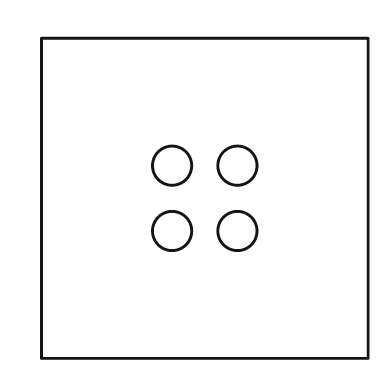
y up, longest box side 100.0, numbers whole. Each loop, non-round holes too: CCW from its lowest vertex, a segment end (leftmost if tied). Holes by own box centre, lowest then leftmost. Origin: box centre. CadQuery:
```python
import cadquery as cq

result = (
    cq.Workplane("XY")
    .moveTo(-50.0, -49.0)
    .lineTo(50.0, -49.0)
    .lineTo(50.0, 49.0)
    .lineTo(-50.0, 49.0)
    .close()
    .moveTo(-10.0, -10.0)
    .circle(6.0)
    .moveTo(10.0, -10.0)
    .circle(6.0)
    .moveTo(-10.0, 10.0)
    .circle(6.0)
    .moveTo(10.0, 10.0)
    .circle(6.0)
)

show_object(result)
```